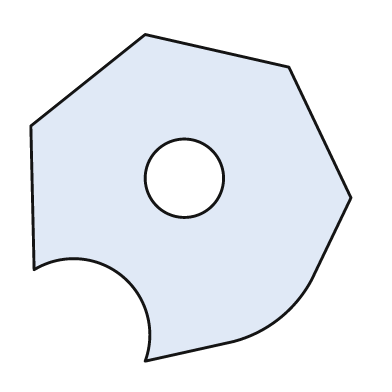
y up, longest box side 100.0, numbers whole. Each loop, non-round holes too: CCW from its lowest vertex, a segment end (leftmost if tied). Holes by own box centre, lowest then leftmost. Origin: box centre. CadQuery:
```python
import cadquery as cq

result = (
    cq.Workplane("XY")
    .moveTo(-14.0, -50.0)
    .lineTo(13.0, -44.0)
    .threePointArc((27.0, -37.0), (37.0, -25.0))
    .lineTo(49.0, 0.0)
    .lineTo(30.0, 40.0)
    .lineTo(-14.0, 50.0)
    .lineTo(-49.0, 22.0)
    .lineTo(-48.0, -22.0)
    .threePointArc((-21.0, -24.0), (-14.0, -50.0))
    .close()
    .moveTo(-2.0, 6.0)
    .circle(12.0)
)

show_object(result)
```